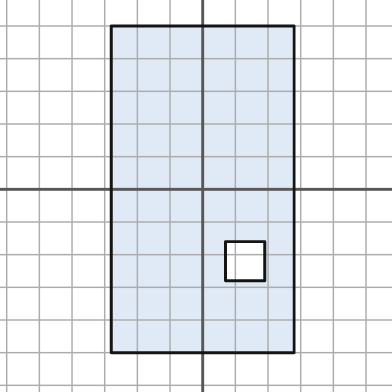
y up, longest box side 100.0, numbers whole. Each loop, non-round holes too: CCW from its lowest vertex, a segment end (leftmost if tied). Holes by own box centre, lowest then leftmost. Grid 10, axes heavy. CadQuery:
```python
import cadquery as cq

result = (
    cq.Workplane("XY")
    .moveTo(-28.0, -50.0)
    .lineTo(28.0, -50.0)
    .lineTo(28.0, 50.0)
    .lineTo(-28.0, 50.0)
    .close()
    .moveTo(7.0, -28.0)
    .lineTo(19.0, -28.0)
    .lineTo(19.0, -16.0)
    .lineTo(7.0, -16.0)
    .close()
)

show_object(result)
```